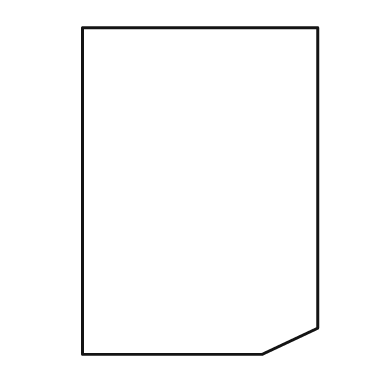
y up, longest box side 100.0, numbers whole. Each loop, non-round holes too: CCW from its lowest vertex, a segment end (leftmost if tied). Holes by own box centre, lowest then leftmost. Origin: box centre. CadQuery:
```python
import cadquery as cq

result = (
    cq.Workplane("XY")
    .moveTo(-36.0, -50.0)
    .lineTo(19.0, -50.0)
    .lineTo(36.0, -42.0)
    .lineTo(36.0, 50.0)
    .lineTo(-36.0, 50.0)
    .close()
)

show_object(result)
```